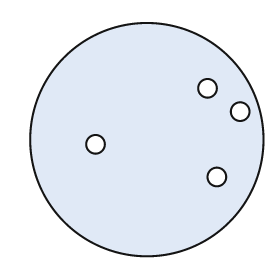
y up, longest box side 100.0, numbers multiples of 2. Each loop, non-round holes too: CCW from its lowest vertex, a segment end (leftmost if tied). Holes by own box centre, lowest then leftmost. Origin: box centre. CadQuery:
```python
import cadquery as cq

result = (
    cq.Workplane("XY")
    .moveTo(0.0, 0.0)
    .circle(50.0)
    .moveTo(30.0, -16.0)
    .circle(4.0)
    .moveTo(-22.0, -2.0)
    .circle(4.0)
    .moveTo(40.0, 12.0)
    .circle(4.0)
    .moveTo(26.0, 22.0)
    .circle(4.0)
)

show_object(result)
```